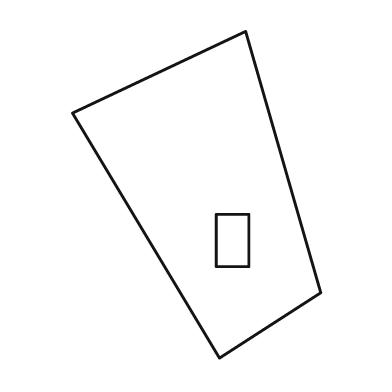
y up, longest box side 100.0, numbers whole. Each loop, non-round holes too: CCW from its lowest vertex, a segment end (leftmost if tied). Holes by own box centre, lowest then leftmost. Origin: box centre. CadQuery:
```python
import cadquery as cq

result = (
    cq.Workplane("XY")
    .moveTo(7.0, -50.0)
    .lineTo(38.0, -30.0)
    .lineTo(15.0, 50.0)
    .lineTo(-38.0, 25.0)
    .close()
    .moveTo(6.0, -22.0)
    .lineTo(16.0, -22.0)
    .lineTo(16.0, -6.0)
    .lineTo(6.0, -6.0)
    .close()
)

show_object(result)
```